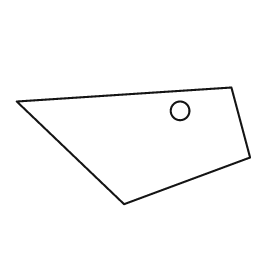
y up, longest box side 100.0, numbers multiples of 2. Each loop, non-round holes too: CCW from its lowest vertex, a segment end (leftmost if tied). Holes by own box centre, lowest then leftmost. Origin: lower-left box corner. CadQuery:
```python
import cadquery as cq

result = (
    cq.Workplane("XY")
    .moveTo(46.0, 0.0)
    .lineTo(100.0, 20.0)
    .lineTo(92.0, 50.0)
    .lineTo(0.0, 44.0)
    .close()
    .moveTo(70.0, 40.0)
    .circle(4.0)
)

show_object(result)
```